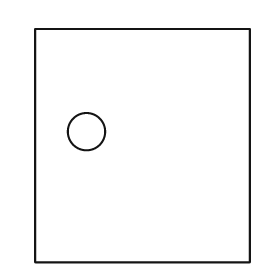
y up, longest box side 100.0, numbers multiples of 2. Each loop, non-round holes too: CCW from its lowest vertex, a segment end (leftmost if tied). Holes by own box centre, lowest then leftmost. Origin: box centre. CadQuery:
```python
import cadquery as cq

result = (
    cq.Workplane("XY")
    .moveTo(-46.0, -50.0)
    .lineTo(46.0, -50.0)
    .lineTo(46.0, 50.0)
    .lineTo(-46.0, 50.0)
    .close()
    .moveTo(-24.0, 6.0)
    .circle(8.0)
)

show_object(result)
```